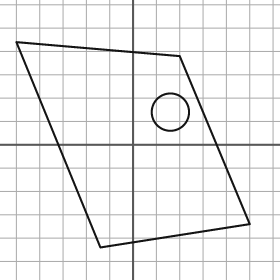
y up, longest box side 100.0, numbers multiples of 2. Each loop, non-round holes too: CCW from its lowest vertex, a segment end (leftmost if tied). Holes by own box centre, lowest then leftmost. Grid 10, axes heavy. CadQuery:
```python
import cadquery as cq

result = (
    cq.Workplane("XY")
    .moveTo(-14.0, -44.0)
    .lineTo(50.0, -34.0)
    .lineTo(20.0, 38.0)
    .lineTo(-50.0, 44.0)
    .close()
    .moveTo(16.0, 14.0)
    .circle(8.0)
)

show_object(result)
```